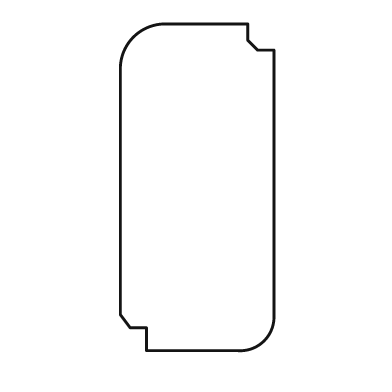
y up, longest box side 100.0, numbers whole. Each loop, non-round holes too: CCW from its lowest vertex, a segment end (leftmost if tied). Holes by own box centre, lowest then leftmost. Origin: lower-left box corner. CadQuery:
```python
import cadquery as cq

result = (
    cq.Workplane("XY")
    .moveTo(8.0, 0.0)
    .lineTo(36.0, 0.0)
    .threePointArc((44.0, 3.0), (47.0, 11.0))
    .lineTo(47.0, 92.0)
    .lineTo(42.0, 92.0)
    .lineTo(39.0, 95.0)
    .lineTo(39.0, 100.0)
    .lineTo(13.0, 100.0)
    .threePointArc((4.0, 96.0), (0.0, 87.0))
    .lineTo(0.0, 11.0)
    .lineTo(3.0, 7.0)
    .lineTo(8.0, 7.0)
    .close()
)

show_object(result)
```